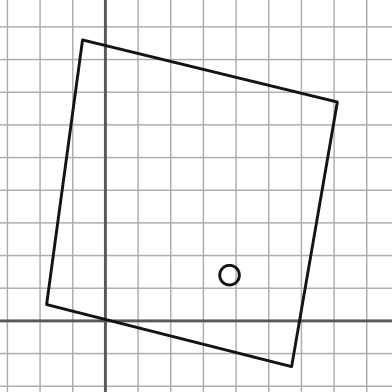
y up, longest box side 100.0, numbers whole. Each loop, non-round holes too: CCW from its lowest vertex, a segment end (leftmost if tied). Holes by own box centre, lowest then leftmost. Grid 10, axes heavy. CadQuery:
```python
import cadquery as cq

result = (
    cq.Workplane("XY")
    .moveTo(57.0, -14.0)
    .lineTo(71.0, 67.0)
    .lineTo(-7.0, 86.0)
    .lineTo(-18.0, 5.0)
    .close()
    .moveTo(38.0, 14.0)
    .circle(3.0)
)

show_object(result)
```